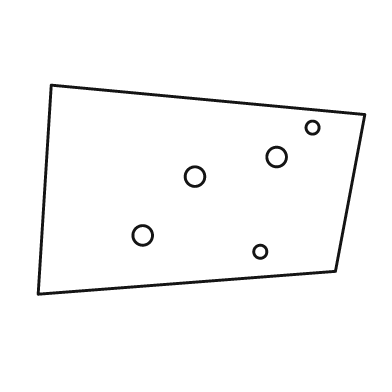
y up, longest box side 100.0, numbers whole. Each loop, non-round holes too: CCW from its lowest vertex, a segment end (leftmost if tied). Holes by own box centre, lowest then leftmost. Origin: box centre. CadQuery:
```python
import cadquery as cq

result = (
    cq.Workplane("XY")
    .moveTo(-50.0, -32.0)
    .lineTo(41.0, -25.0)
    .lineTo(50.0, 23.0)
    .lineTo(-46.0, 32.0)
    .close()
    .moveTo(18.0, -19.0)
    .circle(2.0)
    .moveTo(-18.0, -14.0)
    .circle(3.0)
    .moveTo(-2.0, 4.0)
    .circle(3.0)
    .moveTo(23.0, 10.0)
    .circle(3.0)
    .moveTo(34.0, 19.0)
    .circle(2.0)
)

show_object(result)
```